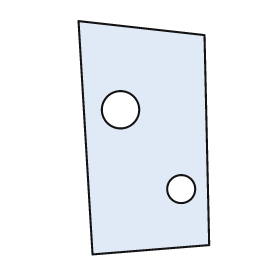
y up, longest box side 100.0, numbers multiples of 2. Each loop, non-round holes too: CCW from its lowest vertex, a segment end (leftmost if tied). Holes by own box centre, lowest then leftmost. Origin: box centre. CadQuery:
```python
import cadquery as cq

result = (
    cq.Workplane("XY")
    .moveTo(-22.0, -50.0)
    .lineTo(28.0, -46.0)
    .lineTo(26.0, 44.0)
    .lineTo(-28.0, 50.0)
    .close()
    .moveTo(16.0, -22.0)
    .circle(6.0)
    .moveTo(-10.0, 12.0)
    .circle(8.0)
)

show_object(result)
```